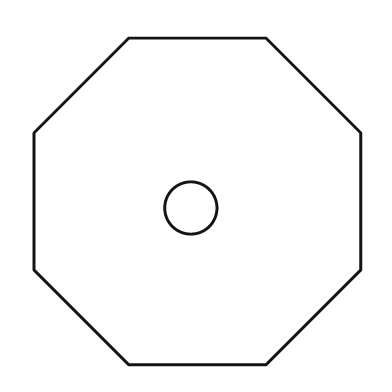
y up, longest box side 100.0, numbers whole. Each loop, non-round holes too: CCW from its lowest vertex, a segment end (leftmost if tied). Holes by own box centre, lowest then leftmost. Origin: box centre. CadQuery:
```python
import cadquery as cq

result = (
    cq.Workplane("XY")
    .moveTo(-21.0, -50.0)
    .lineTo(21.0, -50.0)
    .lineTo(50.0, -21.0)
    .lineTo(50.0, 21.0)
    .lineTo(21.0, 50.0)
    .lineTo(-21.0, 50.0)
    .lineTo(-50.0, 21.0)
    .lineTo(-50.0, -21.0)
    .close()
    .moveTo(-2.0, -2.0)
    .circle(8.0)
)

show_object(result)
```